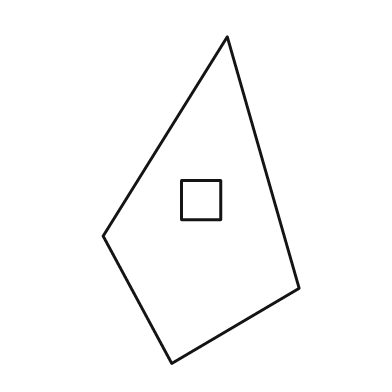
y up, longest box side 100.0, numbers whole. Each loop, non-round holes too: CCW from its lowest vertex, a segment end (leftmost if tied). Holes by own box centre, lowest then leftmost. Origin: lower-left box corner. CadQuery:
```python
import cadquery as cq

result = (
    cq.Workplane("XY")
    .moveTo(21.0, 0.0)
    .lineTo(60.0, 23.0)
    .lineTo(38.0, 100.0)
    .lineTo(0.0, 39.0)
    .close()
    .moveTo(24.0, 44.0)
    .lineTo(36.0, 44.0)
    .lineTo(36.0, 56.0)
    .lineTo(24.0, 56.0)
    .close()
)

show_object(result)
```